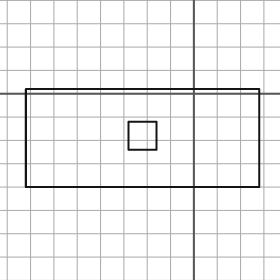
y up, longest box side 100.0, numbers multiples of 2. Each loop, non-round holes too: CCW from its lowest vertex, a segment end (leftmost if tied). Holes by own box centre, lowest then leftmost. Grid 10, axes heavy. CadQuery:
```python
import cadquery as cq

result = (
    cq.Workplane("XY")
    .moveTo(-72.0, -40.0)
    .lineTo(28.0, -40.0)
    .lineTo(28.0, 2.0)
    .lineTo(-72.0, 2.0)
    .close()
    .moveTo(-28.0, -24.0)
    .lineTo(-16.0, -24.0)
    .lineTo(-16.0, -12.0)
    .lineTo(-28.0, -12.0)
    .close()
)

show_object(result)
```